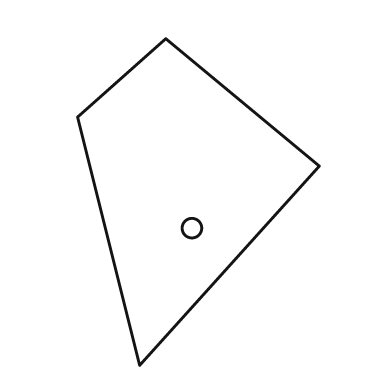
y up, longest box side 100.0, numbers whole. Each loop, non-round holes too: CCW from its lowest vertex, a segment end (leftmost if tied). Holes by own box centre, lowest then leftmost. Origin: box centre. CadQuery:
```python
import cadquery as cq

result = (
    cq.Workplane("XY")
    .moveTo(-18.0, -50.0)
    .lineTo(37.0, 11.0)
    .lineTo(-10.0, 50.0)
    .lineTo(-37.0, 26.0)
    .close()
    .moveTo(-2.0, -8.0)
    .circle(3.0)
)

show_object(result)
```